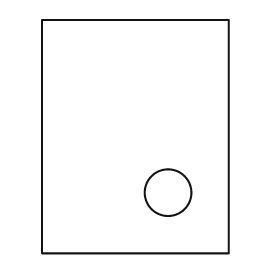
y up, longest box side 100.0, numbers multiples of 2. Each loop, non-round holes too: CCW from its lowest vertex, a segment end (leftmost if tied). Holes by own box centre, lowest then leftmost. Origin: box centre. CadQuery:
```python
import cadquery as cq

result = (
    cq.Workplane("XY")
    .moveTo(-40.0, -50.0)
    .lineTo(40.0, -50.0)
    .lineTo(40.0, 50.0)
    .lineTo(-40.0, 50.0)
    .close()
    .moveTo(14.0, -24.0)
    .circle(10.0)
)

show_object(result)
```